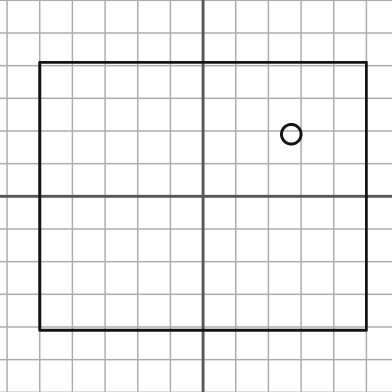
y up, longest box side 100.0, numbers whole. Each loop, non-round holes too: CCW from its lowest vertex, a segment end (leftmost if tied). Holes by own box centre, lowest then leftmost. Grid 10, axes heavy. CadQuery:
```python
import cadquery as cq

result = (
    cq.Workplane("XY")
    .moveTo(-50.0, -41.0)
    .lineTo(50.0, -41.0)
    .lineTo(50.0, 41.0)
    .lineTo(-50.0, 41.0)
    .close()
    .moveTo(27.0, 19.0)
    .circle(3.0)
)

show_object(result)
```